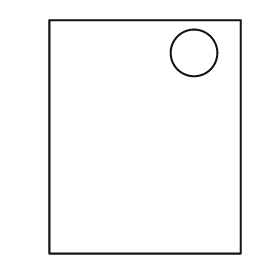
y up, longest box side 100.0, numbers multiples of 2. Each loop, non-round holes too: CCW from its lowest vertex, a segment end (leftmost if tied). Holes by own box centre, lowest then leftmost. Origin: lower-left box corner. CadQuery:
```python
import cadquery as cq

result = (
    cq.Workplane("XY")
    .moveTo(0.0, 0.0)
    .lineTo(82.0, 0.0)
    .lineTo(82.0, 100.0)
    .lineTo(0.0, 100.0)
    .close()
    .moveTo(62.0, 86.0)
    .circle(10.0)
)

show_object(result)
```